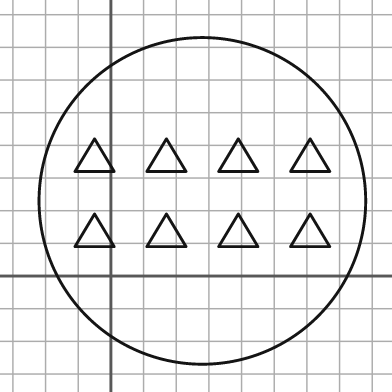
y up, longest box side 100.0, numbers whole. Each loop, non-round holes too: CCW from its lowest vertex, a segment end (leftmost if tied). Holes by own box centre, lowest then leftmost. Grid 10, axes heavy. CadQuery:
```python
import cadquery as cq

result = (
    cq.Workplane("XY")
    .moveTo(28.0, 23.0)
    .circle(50.0)
    .moveTo(-11.0, 9.0)
    .lineTo(1.0, 9.0)
    .lineTo(-5.0, 19.0)
    .close()
    .moveTo(11.0, 9.0)
    .lineTo(23.0, 9.0)
    .lineTo(17.0, 19.0)
    .close()
    .moveTo(33.0, 9.0)
    .lineTo(45.0, 9.0)
    .lineTo(39.0, 19.0)
    .close()
    .moveTo(55.0, 9.0)
    .lineTo(67.0, 9.0)
    .lineTo(61.0, 19.0)
    .close()
    .moveTo(-11.0, 32.0)
    .lineTo(1.0, 32.0)
    .lineTo(-5.0, 42.0)
    .close()
    .moveTo(11.0, 32.0)
    .lineTo(23.0, 32.0)
    .lineTo(17.0, 42.0)
    .close()
    .moveTo(33.0, 32.0)
    .lineTo(45.0, 32.0)
    .lineTo(39.0, 42.0)
    .close()
    .moveTo(55.0, 32.0)
    .lineTo(67.0, 32.0)
    .lineTo(61.0, 42.0)
    .close()
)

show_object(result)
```